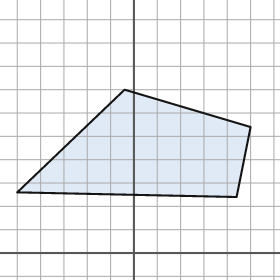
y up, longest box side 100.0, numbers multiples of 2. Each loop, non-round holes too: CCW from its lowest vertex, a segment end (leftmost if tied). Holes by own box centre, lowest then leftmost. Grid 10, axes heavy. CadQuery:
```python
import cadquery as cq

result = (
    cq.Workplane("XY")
    .moveTo(44.0, 24.0)
    .lineTo(50.0, 54.0)
    .lineTo(-4.0, 70.0)
    .lineTo(-50.0, 26.0)
    .close()
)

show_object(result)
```